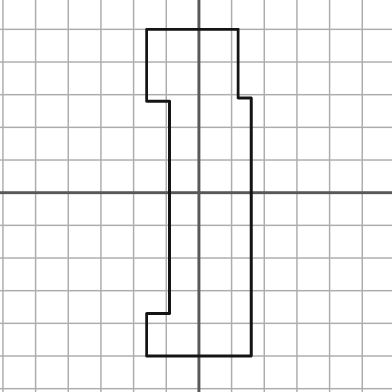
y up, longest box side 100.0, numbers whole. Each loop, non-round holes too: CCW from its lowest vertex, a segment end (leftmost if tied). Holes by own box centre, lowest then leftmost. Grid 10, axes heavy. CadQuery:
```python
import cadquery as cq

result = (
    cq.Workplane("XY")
    .moveTo(-16.0, -50.0)
    .lineTo(16.0, -50.0)
    .lineTo(16.0, 29.0)
    .lineTo(12.0, 29.0)
    .lineTo(12.0, 50.0)
    .lineTo(-16.0, 50.0)
    .lineTo(-16.0, 28.0)
    .lineTo(-9.0, 28.0)
    .lineTo(-9.0, -37.0)
    .lineTo(-16.0, -37.0)
    .close()
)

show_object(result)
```